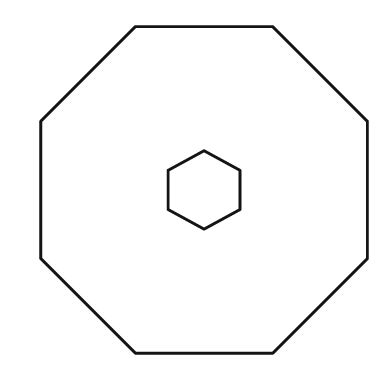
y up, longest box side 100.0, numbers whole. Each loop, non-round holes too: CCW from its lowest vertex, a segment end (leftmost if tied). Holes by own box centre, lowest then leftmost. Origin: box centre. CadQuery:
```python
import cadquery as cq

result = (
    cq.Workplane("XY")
    .moveTo(-21.0, -50.0)
    .lineTo(21.0, -50.0)
    .lineTo(50.0, -21.0)
    .lineTo(50.0, 21.0)
    .lineTo(21.0, 50.0)
    .lineTo(-21.0, 50.0)
    .lineTo(-50.0, 21.0)
    .lineTo(-50.0, -21.0)
    .close()
    .moveTo(0.0, -12.0)
    .lineTo(11.0, -6.0)
    .lineTo(11.0, 6.0)
    .lineTo(0.0, 12.0)
    .lineTo(-11.0, 6.0)
    .lineTo(-11.0, -6.0)
    .close()
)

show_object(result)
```